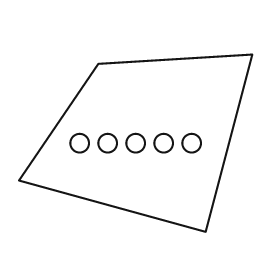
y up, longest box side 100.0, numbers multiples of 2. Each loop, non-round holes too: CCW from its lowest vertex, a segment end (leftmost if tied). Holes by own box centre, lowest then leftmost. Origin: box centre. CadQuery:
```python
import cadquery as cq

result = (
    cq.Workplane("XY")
    .moveTo(30.0, -38.0)
    .lineTo(50.0, 38.0)
    .lineTo(-16.0, 34.0)
    .lineTo(-50.0, -16.0)
    .close()
    .moveTo(-24.0, 0.0)
    .circle(4.0)
    .moveTo(-12.0, 0.0)
    .circle(4.0)
    .moveTo(0.0, 0.0)
    .circle(4.0)
    .moveTo(12.0, 0.0)
    .circle(4.0)
    .moveTo(24.0, 0.0)
    .circle(4.0)
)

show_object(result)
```